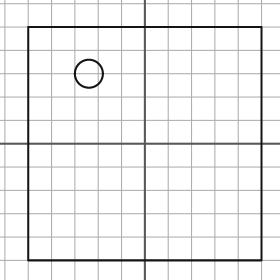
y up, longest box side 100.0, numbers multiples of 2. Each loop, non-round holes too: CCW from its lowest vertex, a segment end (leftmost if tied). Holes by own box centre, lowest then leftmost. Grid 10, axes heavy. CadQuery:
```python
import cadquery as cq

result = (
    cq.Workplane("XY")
    .moveTo(-50.0, -50.0)
    .lineTo(50.0, -50.0)
    .lineTo(50.0, 50.0)
    .lineTo(-50.0, 50.0)
    .close()
    .moveTo(-24.0, 30.0)
    .circle(6.0)
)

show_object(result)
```